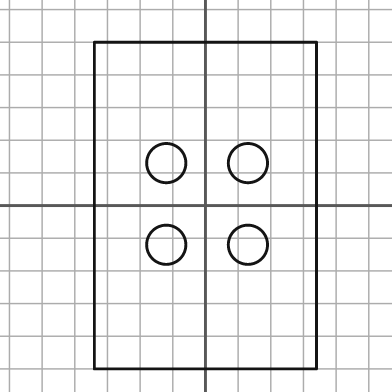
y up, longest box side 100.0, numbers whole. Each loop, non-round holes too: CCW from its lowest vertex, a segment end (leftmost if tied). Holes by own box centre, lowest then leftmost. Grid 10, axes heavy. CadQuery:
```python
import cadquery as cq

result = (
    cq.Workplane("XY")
    .moveTo(-34.0, -50.0)
    .lineTo(34.0, -50.0)
    .lineTo(34.0, 50.0)
    .lineTo(-34.0, 50.0)
    .close()
    .moveTo(-12.0, -12.0)
    .circle(6.0)
    .moveTo(13.0, -12.0)
    .circle(6.0)
    .moveTo(-12.0, 13.0)
    .circle(6.0)
    .moveTo(13.0, 13.0)
    .circle(6.0)
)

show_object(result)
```